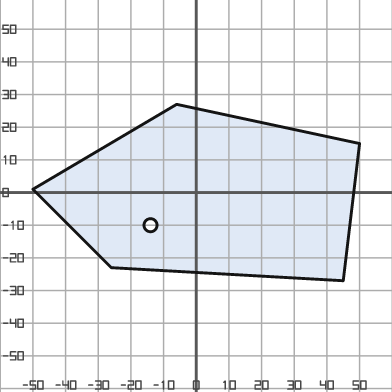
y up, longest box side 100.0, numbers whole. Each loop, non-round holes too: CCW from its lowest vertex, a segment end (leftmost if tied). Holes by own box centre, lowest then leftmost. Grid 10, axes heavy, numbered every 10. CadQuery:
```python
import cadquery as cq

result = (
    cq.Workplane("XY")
    .moveTo(45.0, -27.0)
    .lineTo(50.0, 15.0)
    .lineTo(-6.0, 27.0)
    .lineTo(-50.0, 1.0)
    .lineTo(-26.0, -23.0)
    .close()
    .moveTo(-14.0, -10.0)
    .circle(2.0)
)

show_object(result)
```